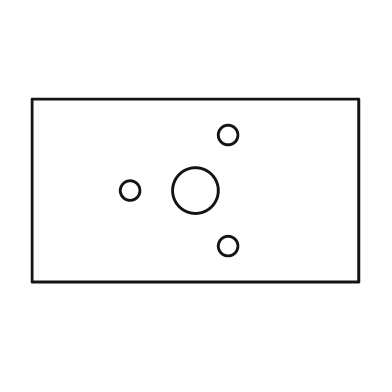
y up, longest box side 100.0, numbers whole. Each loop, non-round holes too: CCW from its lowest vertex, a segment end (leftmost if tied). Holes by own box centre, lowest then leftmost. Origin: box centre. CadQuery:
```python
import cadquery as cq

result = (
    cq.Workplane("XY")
    .moveTo(-50.0, -28.0)
    .lineTo(50.0, -28.0)
    .lineTo(50.0, 28.0)
    .lineTo(-50.0, 28.0)
    .close()
    .moveTo(10.0, -17.0)
    .circle(3.0)
    .moveTo(-20.0, 0.0)
    .circle(3.0)
    .moveTo(0.0, 0.0)
    .circle(7.0)
    .moveTo(10.0, 17.0)
    .circle(3.0)
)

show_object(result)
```